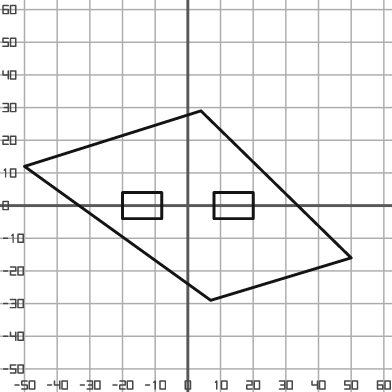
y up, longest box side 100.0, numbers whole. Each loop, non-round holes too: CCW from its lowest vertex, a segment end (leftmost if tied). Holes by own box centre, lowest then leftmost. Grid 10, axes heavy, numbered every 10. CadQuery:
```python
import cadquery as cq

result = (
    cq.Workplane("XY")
    .moveTo(7.0, -29.0)
    .lineTo(50.0, -16.0)
    .lineTo(4.0, 29.0)
    .lineTo(-50.0, 12.0)
    .close()
    .moveTo(-20.0, -4.0)
    .lineTo(-8.0, -4.0)
    .lineTo(-8.0, 4.0)
    .lineTo(-20.0, 4.0)
    .close()
    .moveTo(8.0, -4.0)
    .lineTo(20.0, -4.0)
    .lineTo(20.0, 4.0)
    .lineTo(8.0, 4.0)
    .close()
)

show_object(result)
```